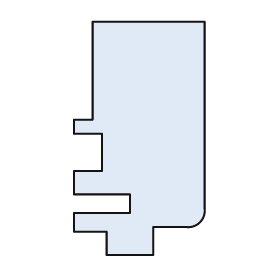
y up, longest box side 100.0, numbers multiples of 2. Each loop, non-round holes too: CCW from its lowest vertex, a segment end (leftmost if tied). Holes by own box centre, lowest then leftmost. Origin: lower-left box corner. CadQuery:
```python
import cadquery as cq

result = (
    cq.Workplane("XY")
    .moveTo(14.0, 0.0)
    .lineTo(34.0, 0.0)
    .lineTo(34.0, 12.0)
    .lineTo(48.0, 12.0)
    .threePointArc((54.0, 14.0), (56.0, 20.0))
    .lineTo(56.0, 100.0)
    .lineTo(8.0, 100.0)
    .lineTo(8.0, 58.0)
    .lineTo(0.0, 58.0)
    .lineTo(0.0, 52.0)
    .lineTo(12.0, 52.0)
    .lineTo(12.0, 36.0)
    .lineTo(0.0, 36.0)
    .lineTo(0.0, 26.0)
    .lineTo(24.0, 26.0)
    .lineTo(24.0, 18.0)
    .lineTo(0.0, 18.0)
    .lineTo(0.0, 10.0)
    .lineTo(14.0, 10.0)
    .close()
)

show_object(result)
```